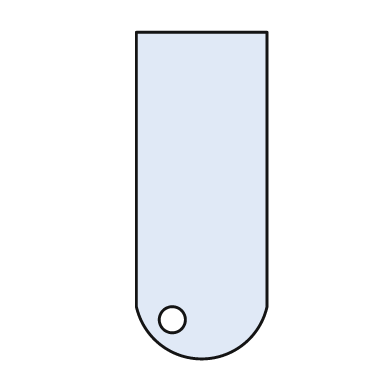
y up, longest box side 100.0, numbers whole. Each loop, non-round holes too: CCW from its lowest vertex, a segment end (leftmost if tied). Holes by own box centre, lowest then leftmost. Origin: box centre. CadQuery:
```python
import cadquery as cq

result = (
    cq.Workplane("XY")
    .moveTo(-20.0, -34.0)
    .threePointArc((0.0, -50.0), (20.0, -34.0))
    .lineTo(20.0, 50.0)
    .lineTo(-20.0, 50.0)
    .close()
    .moveTo(-9.0, -38.0)
    .circle(4.0)
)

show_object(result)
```